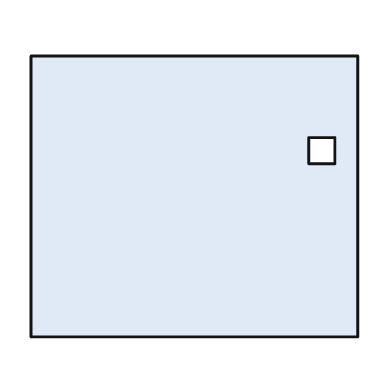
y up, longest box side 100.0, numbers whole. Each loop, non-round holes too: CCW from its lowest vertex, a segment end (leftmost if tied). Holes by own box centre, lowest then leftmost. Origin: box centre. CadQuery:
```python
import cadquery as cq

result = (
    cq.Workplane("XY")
    .moveTo(-50.0, -43.0)
    .lineTo(50.0, -43.0)
    .lineTo(50.0, 43.0)
    .lineTo(-50.0, 43.0)
    .close()
    .moveTo(35.0, 10.0)
    .lineTo(43.0, 10.0)
    .lineTo(43.0, 18.0)
    .lineTo(35.0, 18.0)
    .close()
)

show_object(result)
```